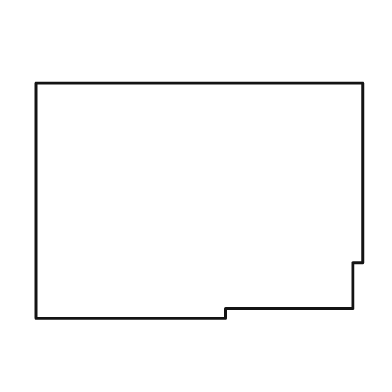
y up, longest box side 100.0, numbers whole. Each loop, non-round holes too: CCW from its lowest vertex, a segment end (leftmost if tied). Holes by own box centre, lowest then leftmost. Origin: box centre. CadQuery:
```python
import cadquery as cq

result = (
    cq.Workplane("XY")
    .moveTo(-50.0, -36.0)
    .lineTo(8.0, -36.0)
    .lineTo(8.0, -33.0)
    .lineTo(47.0, -33.0)
    .lineTo(47.0, -19.0)
    .lineTo(50.0, -19.0)
    .lineTo(50.0, 36.0)
    .lineTo(-50.0, 36.0)
    .close()
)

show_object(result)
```